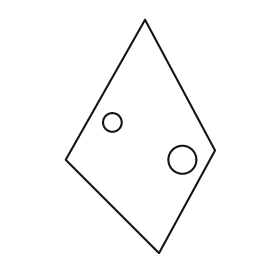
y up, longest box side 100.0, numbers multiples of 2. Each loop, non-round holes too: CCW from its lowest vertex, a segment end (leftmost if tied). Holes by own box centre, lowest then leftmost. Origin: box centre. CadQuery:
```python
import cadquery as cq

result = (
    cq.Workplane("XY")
    .moveTo(8.0, -50.0)
    .lineTo(32.0, -6.0)
    .lineTo(2.0, 50.0)
    .lineTo(-32.0, -10.0)
    .close()
    .moveTo(18.0, -10.0)
    .circle(6.0)
    .moveTo(-12.0, 6.0)
    .circle(4.0)
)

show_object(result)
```